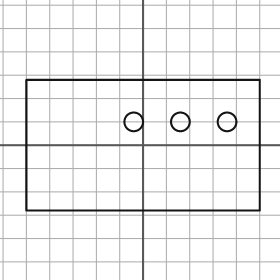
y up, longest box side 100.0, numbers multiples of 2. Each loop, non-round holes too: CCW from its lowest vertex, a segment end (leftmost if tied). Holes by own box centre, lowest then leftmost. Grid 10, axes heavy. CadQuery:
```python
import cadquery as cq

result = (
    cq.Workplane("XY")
    .moveTo(-50.0, -28.0)
    .lineTo(50.0, -28.0)
    .lineTo(50.0, 28.0)
    .lineTo(-50.0, 28.0)
    .close()
    .moveTo(-4.0, 10.0)
    .circle(4.0)
    .moveTo(16.0, 10.0)
    .circle(4.0)
    .moveTo(36.0, 10.0)
    .circle(4.0)
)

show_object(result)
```